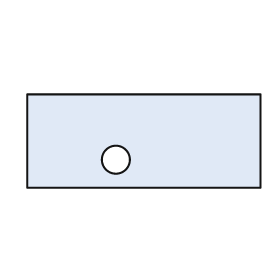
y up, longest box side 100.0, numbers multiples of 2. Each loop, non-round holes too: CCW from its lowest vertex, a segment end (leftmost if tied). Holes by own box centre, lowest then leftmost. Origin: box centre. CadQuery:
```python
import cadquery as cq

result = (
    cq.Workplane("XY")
    .moveTo(-50.0, -20.0)
    .lineTo(50.0, -20.0)
    .lineTo(50.0, 20.0)
    .lineTo(-50.0, 20.0)
    .close()
    .moveTo(-12.0, -8.0)
    .circle(6.0)
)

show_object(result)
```